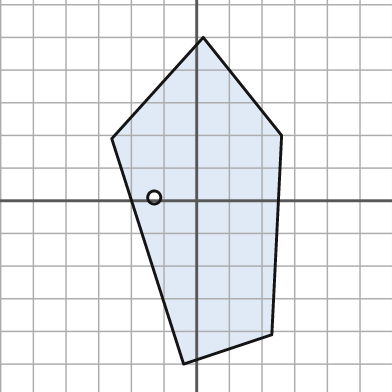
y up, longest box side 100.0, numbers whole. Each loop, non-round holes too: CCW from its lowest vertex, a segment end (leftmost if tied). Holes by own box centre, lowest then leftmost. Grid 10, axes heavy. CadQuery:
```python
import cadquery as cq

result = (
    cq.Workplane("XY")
    .moveTo(-4.0, -50.0)
    .lineTo(23.0, -41.0)
    .lineTo(26.0, 20.0)
    .lineTo(2.0, 50.0)
    .lineTo(-26.0, 19.0)
    .close()
    .moveTo(-13.0, 1.0)
    .circle(2.0)
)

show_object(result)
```